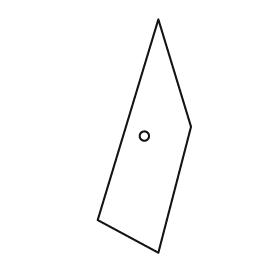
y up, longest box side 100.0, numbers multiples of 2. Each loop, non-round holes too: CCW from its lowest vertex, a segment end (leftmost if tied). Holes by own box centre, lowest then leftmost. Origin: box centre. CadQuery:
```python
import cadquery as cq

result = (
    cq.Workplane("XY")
    .moveTo(6.0, -50.0)
    .lineTo(20.0, 4.0)
    .lineTo(6.0, 50.0)
    .lineTo(-20.0, -36.0)
    .close()
    .moveTo(0.0, 0.0)
    .circle(2.0)
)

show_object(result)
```